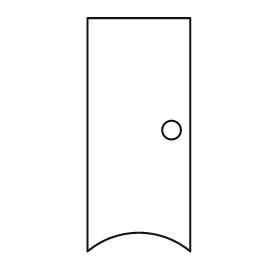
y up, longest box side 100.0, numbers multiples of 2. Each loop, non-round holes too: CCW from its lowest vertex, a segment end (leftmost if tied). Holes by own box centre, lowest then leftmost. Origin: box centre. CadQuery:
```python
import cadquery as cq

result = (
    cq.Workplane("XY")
    .moveTo(-22.0, -50.0)
    .threePointArc((0.0, -42.0), (22.0, -50.0))
    .lineTo(22.0, 50.0)
    .lineTo(-22.0, 50.0)
    .close()
    .moveTo(14.0, 2.0)
    .circle(4.0)
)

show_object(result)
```